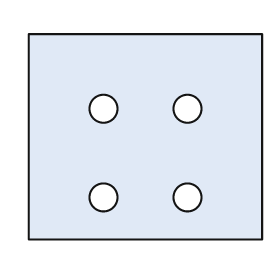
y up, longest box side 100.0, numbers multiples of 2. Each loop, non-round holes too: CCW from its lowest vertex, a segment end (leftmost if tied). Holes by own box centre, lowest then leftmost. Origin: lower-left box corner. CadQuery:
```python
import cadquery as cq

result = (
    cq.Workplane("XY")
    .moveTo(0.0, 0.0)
    .lineTo(100.0, 0.0)
    .lineTo(100.0, 88.0)
    .lineTo(0.0, 88.0)
    .close()
    .moveTo(32.0, 18.0)
    .circle(6.0)
    .moveTo(68.0, 18.0)
    .circle(6.0)
    .moveTo(32.0, 56.0)
    .circle(6.0)
    .moveTo(68.0, 56.0)
    .circle(6.0)
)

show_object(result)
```